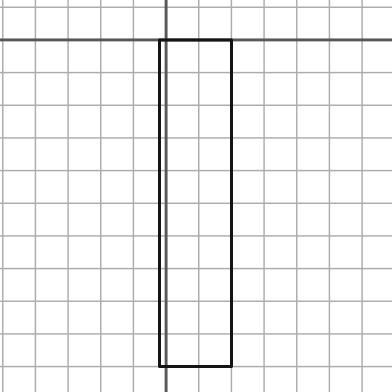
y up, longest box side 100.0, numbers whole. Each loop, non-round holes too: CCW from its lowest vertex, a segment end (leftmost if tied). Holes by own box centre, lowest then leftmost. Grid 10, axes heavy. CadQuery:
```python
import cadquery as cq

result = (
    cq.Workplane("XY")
    .moveTo(-2.0, -100.0)
    .lineTo(20.0, -100.0)
    .lineTo(20.0, 0.0)
    .lineTo(-2.0, 0.0)
    .close()
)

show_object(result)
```